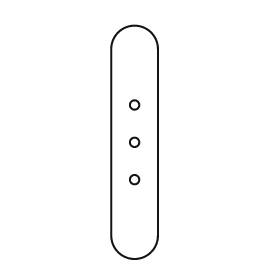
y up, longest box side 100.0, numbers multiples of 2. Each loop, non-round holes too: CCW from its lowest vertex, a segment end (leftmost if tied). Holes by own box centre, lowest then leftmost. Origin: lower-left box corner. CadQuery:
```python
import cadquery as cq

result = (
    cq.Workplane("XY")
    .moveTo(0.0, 10.0)
    .threePointArc((10.0, 0.0), (20.0, 10.0))
    .lineTo(20.0, 90.0)
    .threePointArc((10.0, 100.0), (0.0, 90.0))
    .close()
    .moveTo(10.0, 34.0)
    .circle(2.0)
    .moveTo(10.0, 50.0)
    .circle(2.0)
    .moveTo(10.0, 66.0)
    .circle(2.0)
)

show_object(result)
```